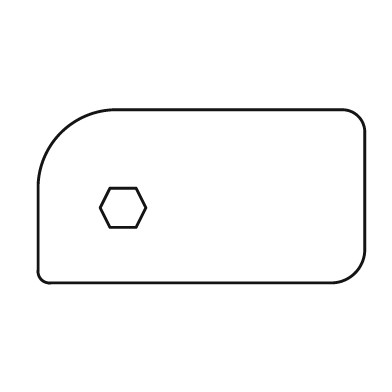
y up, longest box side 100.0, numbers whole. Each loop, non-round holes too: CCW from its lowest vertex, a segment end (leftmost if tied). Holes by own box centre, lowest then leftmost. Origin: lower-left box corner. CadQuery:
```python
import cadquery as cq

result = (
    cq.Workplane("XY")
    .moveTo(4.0, 0.0)
    .lineTo(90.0, 0.0)
    .threePointArc((97.0, 3.0), (100.0, 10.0))
    .lineTo(100.0, 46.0)
    .threePointArc((98.0, 51.0), (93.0, 53.0))
    .lineTo(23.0, 53.0)
    .threePointArc((7.0, 46.0), (0.0, 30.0))
    .lineTo(0.0, 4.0)
    .threePointArc((1.0, 1.0), (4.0, 0.0))
    .close()
    .moveTo(22.0, 17.0)
    .lineTo(30.0, 17.0)
    .lineTo(33.0, 23.0)
    .lineTo(30.0, 29.0)
    .lineTo(22.0, 29.0)
    .lineTo(19.0, 23.0)
    .close()
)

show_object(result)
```